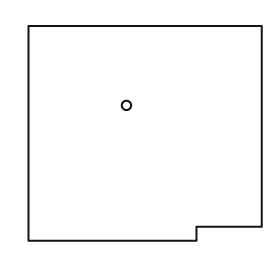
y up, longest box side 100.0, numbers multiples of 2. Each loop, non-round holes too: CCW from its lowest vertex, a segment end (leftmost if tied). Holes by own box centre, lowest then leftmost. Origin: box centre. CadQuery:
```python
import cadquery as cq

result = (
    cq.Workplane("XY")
    .moveTo(-50.0, -46.0)
    .lineTo(22.0, -46.0)
    .lineTo(22.0, -40.0)
    .lineTo(50.0, -40.0)
    .lineTo(50.0, 46.0)
    .lineTo(-50.0, 46.0)
    .close()
    .moveTo(-8.0, 12.0)
    .circle(2.0)
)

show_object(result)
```